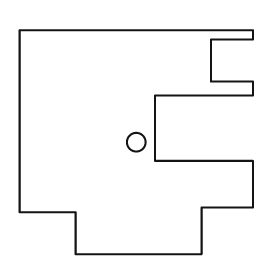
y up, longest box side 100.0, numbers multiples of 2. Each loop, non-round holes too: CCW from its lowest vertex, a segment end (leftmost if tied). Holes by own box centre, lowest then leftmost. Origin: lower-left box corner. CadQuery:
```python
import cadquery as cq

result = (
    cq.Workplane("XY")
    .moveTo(24.0, 0.0)
    .lineTo(78.0, 0.0)
    .lineTo(78.0, 20.0)
    .lineTo(100.0, 20.0)
    .lineTo(100.0, 40.0)
    .lineTo(58.0, 40.0)
    .lineTo(58.0, 68.0)
    .lineTo(100.0, 68.0)
    .lineTo(100.0, 74.0)
    .lineTo(82.0, 74.0)
    .lineTo(82.0, 92.0)
    .lineTo(100.0, 92.0)
    .lineTo(100.0, 96.0)
    .lineTo(0.0, 96.0)
    .lineTo(0.0, 18.0)
    .lineTo(24.0, 18.0)
    .close()
    .moveTo(50.0, 48.0)
    .circle(4.0)
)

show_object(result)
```